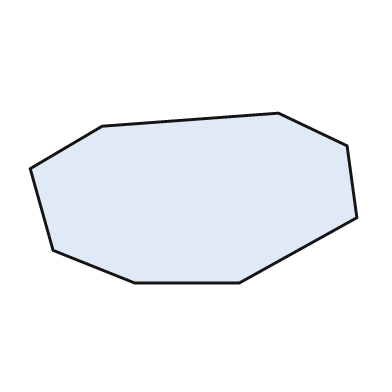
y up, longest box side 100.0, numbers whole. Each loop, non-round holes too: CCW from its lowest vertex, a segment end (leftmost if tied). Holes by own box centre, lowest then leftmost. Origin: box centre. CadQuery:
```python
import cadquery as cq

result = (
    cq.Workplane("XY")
    .moveTo(-18.0, -26.0)
    .lineTo(14.0, -26.0)
    .lineTo(50.0, -6.0)
    .lineTo(47.0, 16.0)
    .lineTo(26.0, 26.0)
    .lineTo(-28.0, 22.0)
    .lineTo(-50.0, 9.0)
    .lineTo(-43.0, -16.0)
    .close()
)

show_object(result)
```